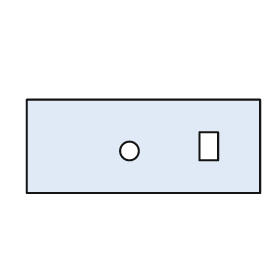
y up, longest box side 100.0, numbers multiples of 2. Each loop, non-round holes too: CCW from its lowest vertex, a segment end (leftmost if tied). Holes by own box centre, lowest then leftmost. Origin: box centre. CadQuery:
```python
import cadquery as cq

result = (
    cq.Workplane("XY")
    .moveTo(-50.0, -20.0)
    .lineTo(50.0, -20.0)
    .lineTo(50.0, 20.0)
    .lineTo(-50.0, 20.0)
    .close()
    .moveTo(-6.0, -2.0)
    .circle(4.0)
    .moveTo(24.0, -6.0)
    .lineTo(32.0, -6.0)
    .lineTo(32.0, 6.0)
    .lineTo(24.0, 6.0)
    .close()
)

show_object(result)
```